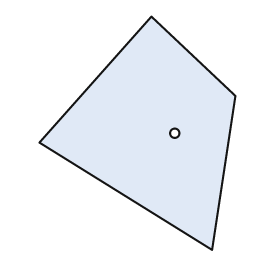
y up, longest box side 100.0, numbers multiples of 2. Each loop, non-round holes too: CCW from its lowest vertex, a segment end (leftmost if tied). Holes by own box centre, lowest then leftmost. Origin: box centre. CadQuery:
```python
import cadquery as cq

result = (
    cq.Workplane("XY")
    .moveTo(32.0, -50.0)
    .lineTo(42.0, 16.0)
    .lineTo(6.0, 50.0)
    .lineTo(-42.0, -4.0)
    .close()
    .moveTo(16.0, 0.0)
    .circle(2.0)
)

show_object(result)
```